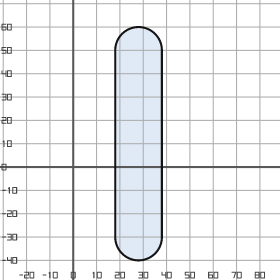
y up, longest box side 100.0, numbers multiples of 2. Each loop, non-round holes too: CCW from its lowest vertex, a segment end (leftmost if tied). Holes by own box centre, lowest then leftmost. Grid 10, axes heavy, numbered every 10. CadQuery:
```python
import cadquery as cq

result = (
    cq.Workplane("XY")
    .moveTo(18.0, -30.0)
    .threePointArc((28.0, -40.0), (38.0, -30.0))
    .lineTo(38.0, 50.0)
    .threePointArc((28.0, 60.0), (18.0, 50.0))
    .close()
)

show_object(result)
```